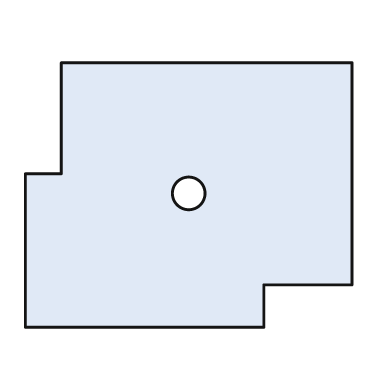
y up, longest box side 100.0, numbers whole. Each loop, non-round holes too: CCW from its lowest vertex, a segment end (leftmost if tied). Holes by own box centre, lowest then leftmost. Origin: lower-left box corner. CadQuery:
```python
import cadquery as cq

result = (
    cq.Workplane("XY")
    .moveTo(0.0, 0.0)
    .lineTo(73.0, 0.0)
    .lineTo(73.0, 13.0)
    .lineTo(100.0, 13.0)
    .lineTo(100.0, 81.0)
    .lineTo(11.0, 81.0)
    .lineTo(11.0, 47.0)
    .lineTo(0.0, 47.0)
    .close()
    .moveTo(50.0, 41.0)
    .circle(5.0)
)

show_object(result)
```